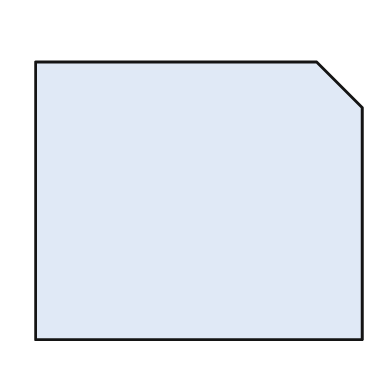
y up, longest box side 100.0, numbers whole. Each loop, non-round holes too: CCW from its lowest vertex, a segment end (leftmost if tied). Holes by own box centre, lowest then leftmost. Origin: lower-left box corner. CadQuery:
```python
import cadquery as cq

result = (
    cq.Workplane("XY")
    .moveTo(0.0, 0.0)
    .lineTo(100.0, 0.0)
    .lineTo(100.0, 71.0)
    .lineTo(86.0, 85.0)
    .lineTo(0.0, 85.0)
    .close()
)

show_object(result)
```